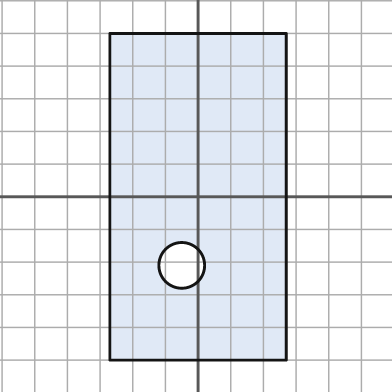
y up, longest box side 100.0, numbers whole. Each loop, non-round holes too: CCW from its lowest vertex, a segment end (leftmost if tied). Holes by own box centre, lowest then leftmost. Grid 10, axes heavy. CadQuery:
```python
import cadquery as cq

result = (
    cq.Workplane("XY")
    .moveTo(-27.0, -50.0)
    .lineTo(27.0, -50.0)
    .lineTo(27.0, 50.0)
    .lineTo(-27.0, 50.0)
    .close()
    .moveTo(-5.0, -21.0)
    .circle(7.0)
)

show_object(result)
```